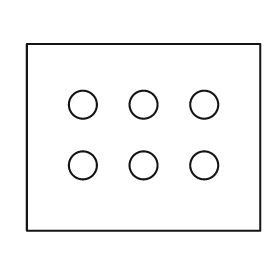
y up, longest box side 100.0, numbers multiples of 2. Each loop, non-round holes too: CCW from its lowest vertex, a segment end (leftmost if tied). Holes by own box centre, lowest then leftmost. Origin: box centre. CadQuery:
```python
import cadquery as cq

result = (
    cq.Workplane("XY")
    .moveTo(-50.0, -40.0)
    .lineTo(50.0, -40.0)
    .lineTo(50.0, 40.0)
    .lineTo(-50.0, 40.0)
    .close()
    .moveTo(-26.0, -12.0)
    .circle(6.0)
    .moveTo(0.0, -12.0)
    .circle(6.0)
    .moveTo(26.0, -12.0)
    .circle(6.0)
    .moveTo(-26.0, 14.0)
    .circle(6.0)
    .moveTo(0.0, 14.0)
    .circle(6.0)
    .moveTo(26.0, 14.0)
    .circle(6.0)
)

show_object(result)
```